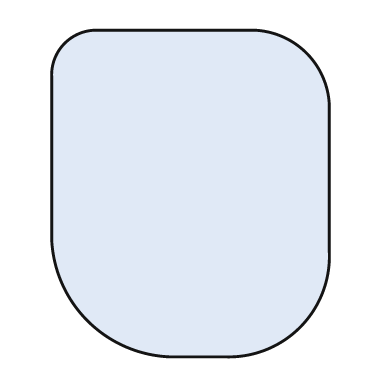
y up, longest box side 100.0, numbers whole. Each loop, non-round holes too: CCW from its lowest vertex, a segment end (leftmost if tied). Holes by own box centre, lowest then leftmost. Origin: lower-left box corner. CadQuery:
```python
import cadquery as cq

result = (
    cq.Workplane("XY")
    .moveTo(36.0, 0.0)
    .lineTo(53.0, 0.0)
    .threePointArc((76.0, 9.0), (85.0, 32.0))
    .lineTo(85.0, 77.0)
    .threePointArc((78.0, 93.0), (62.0, 100.0))
    .lineTo(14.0, 100.0)
    .threePointArc((4.0, 96.0), (0.0, 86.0))
    .lineTo(0.0, 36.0)
    .threePointArc((11.0, 11.0), (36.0, 0.0))
    .close()
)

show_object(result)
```